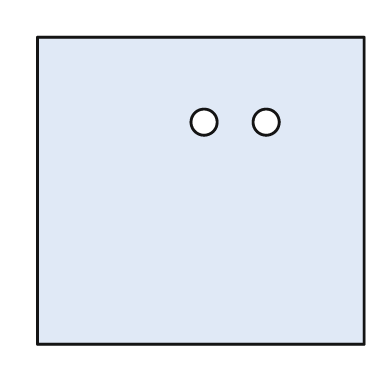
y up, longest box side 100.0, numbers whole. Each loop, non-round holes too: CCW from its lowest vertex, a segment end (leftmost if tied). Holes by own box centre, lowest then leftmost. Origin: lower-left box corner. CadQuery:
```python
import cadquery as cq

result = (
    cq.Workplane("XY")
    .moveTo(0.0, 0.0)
    .lineTo(100.0, 0.0)
    .lineTo(100.0, 94.0)
    .lineTo(0.0, 94.0)
    .close()
    .moveTo(51.0, 68.0)
    .circle(4.0)
    .moveTo(70.0, 68.0)
    .circle(4.0)
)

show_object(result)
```